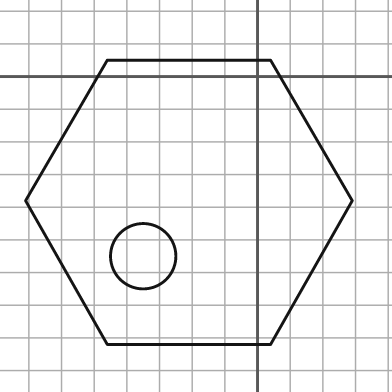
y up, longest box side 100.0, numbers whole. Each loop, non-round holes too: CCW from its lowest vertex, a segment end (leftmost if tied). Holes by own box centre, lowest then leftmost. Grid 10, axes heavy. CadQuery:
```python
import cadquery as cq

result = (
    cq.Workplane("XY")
    .moveTo(-46.0, -82.0)
    .lineTo(4.0, -82.0)
    .lineTo(29.0, -38.0)
    .lineTo(4.0, 5.0)
    .lineTo(-46.0, 5.0)
    .lineTo(-71.0, -38.0)
    .close()
    .moveTo(-35.0, -55.0)
    .circle(10.0)
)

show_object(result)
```